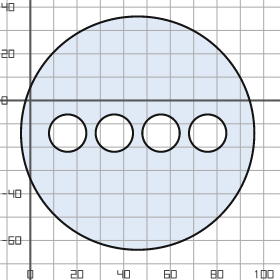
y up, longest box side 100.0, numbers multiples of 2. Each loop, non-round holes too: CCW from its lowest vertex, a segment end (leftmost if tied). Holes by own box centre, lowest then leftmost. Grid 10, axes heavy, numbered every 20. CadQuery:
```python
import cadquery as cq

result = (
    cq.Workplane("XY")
    .moveTo(46.0, -14.0)
    .circle(50.0)
    .moveTo(16.0, -14.0)
    .circle(8.0)
    .moveTo(36.0, -14.0)
    .circle(8.0)
    .moveTo(56.0, -14.0)
    .circle(8.0)
    .moveTo(76.0, -14.0)
    .circle(8.0)
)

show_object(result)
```